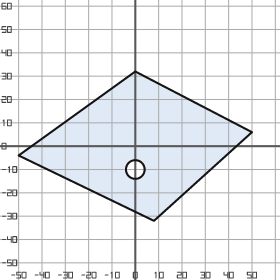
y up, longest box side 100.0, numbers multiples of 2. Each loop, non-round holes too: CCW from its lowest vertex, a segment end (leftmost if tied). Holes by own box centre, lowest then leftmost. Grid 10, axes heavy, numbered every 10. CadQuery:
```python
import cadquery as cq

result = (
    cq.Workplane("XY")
    .moveTo(8.0, -32.0)
    .lineTo(50.0, 6.0)
    .lineTo(0.0, 32.0)
    .lineTo(-50.0, -4.0)
    .close()
    .moveTo(0.0, -10.0)
    .circle(4.0)
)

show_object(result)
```